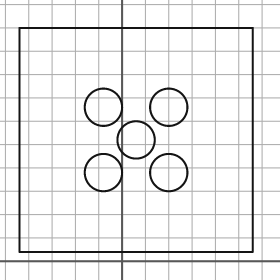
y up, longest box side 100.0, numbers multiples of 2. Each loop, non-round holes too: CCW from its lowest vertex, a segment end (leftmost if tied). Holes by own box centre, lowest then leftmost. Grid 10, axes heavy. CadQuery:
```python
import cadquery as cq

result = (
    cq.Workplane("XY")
    .moveTo(-44.0, 4.0)
    .lineTo(56.0, 4.0)
    .lineTo(56.0, 100.0)
    .lineTo(-44.0, 100.0)
    .close()
    .moveTo(-8.0, 38.0)
    .circle(8.0)
    .moveTo(20.0, 38.0)
    .circle(8.0)
    .moveTo(6.0, 52.0)
    .circle(8.0)
    .moveTo(-8.0, 66.0)
    .circle(8.0)
    .moveTo(20.0, 66.0)
    .circle(8.0)
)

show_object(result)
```